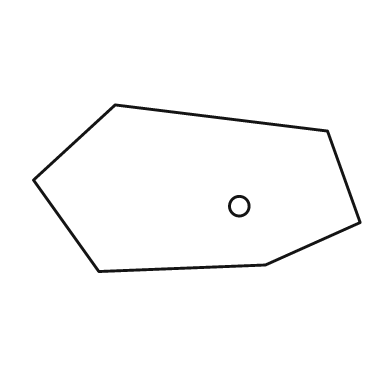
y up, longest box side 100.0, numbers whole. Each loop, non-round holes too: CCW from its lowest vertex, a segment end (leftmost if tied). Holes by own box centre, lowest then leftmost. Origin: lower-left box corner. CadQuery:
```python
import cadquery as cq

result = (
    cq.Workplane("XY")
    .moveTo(20.0, 0.0)
    .lineTo(71.0, 2.0)
    .lineTo(100.0, 15.0)
    .lineTo(90.0, 43.0)
    .lineTo(25.0, 51.0)
    .lineTo(0.0, 28.0)
    .close()
    .moveTo(63.0, 20.0)
    .circle(3.0)
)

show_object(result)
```